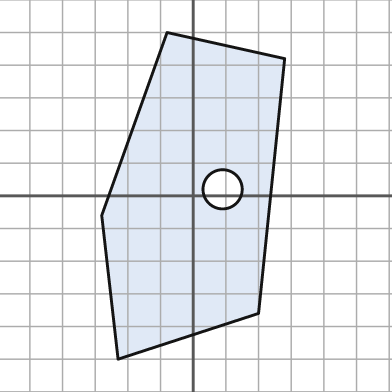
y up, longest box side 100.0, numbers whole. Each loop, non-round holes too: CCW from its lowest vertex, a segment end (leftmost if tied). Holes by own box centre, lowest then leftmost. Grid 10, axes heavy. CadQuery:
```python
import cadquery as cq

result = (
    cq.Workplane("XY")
    .moveTo(-23.0, -50.0)
    .lineTo(20.0, -36.0)
    .lineTo(28.0, 42.0)
    .lineTo(-8.0, 50.0)
    .lineTo(-28.0, -6.0)
    .close()
    .moveTo(9.0, 2.0)
    .circle(6.0)
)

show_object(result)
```